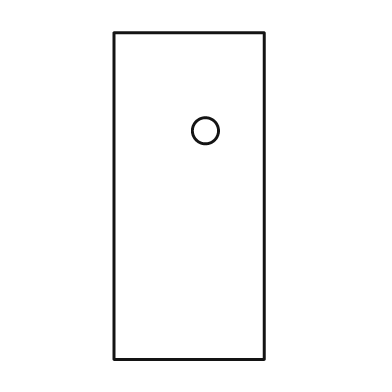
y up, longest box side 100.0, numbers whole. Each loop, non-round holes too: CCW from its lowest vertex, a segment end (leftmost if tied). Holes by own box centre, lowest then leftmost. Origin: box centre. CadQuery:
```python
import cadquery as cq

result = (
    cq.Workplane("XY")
    .moveTo(-23.0, -50.0)
    .lineTo(23.0, -50.0)
    .lineTo(23.0, 50.0)
    .lineTo(-23.0, 50.0)
    .close()
    .moveTo(5.0, 20.0)
    .circle(4.0)
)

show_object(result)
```